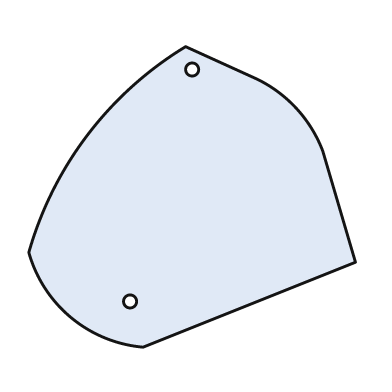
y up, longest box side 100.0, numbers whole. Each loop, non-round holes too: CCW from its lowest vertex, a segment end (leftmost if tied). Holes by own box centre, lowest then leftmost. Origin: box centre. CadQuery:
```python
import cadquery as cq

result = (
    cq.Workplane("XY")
    .moveTo(-15.0, -46.0)
    .lineTo(50.0, -20.0)
    .lineTo(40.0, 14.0)
    .threePointArc((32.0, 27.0), (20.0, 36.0))
    .lineTo(-2.0, 46.0)
    .threePointArc((-32.0, 19.0), (-50.0, -17.0))
    .threePointArc((-37.0, -37.0), (-15.0, -46.0))
    .close()
    .moveTo(-19.0, -32.0)
    .circle(2.0)
    .moveTo(0.0, 39.0)
    .circle(2.0)
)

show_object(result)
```